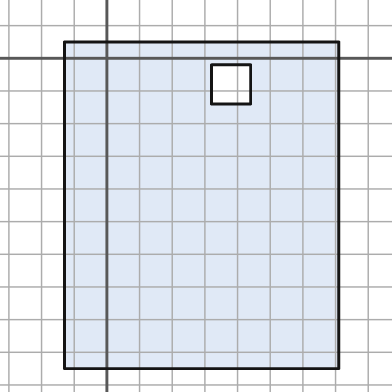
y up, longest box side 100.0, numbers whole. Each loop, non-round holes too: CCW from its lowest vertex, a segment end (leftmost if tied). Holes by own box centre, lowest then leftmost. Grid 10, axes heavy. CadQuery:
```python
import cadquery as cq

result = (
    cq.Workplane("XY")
    .moveTo(-13.0, -95.0)
    .lineTo(71.0, -95.0)
    .lineTo(71.0, 5.0)
    .lineTo(-13.0, 5.0)
    .close()
    .moveTo(32.0, -14.0)
    .lineTo(44.0, -14.0)
    .lineTo(44.0, -2.0)
    .lineTo(32.0, -2.0)
    .close()
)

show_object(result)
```